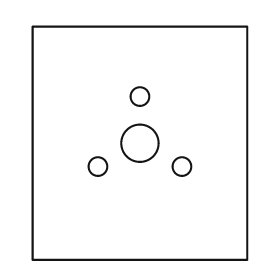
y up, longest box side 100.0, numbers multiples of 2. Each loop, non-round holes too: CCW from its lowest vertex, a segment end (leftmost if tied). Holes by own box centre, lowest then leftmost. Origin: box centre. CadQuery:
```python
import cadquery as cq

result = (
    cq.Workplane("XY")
    .moveTo(-46.0, -50.0)
    .lineTo(46.0, -50.0)
    .lineTo(46.0, 50.0)
    .lineTo(-46.0, 50.0)
    .close()
    .moveTo(-18.0, -10.0)
    .circle(4.0)
    .moveTo(18.0, -10.0)
    .circle(4.0)
    .moveTo(0.0, 0.0)
    .circle(8.0)
    .moveTo(0.0, 20.0)
    .circle(4.0)
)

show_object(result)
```